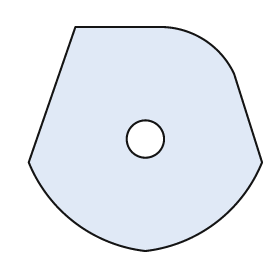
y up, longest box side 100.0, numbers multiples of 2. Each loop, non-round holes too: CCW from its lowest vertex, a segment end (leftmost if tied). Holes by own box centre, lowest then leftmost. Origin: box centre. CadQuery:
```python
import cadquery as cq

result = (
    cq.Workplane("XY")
    .moveTo(0.0, -48.0)
    .threePointArc((30.0, -36.0), (50.0, -10.0))
    .lineTo(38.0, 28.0)
    .threePointArc((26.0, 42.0), (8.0, 48.0))
    .lineTo(-30.0, 48.0)
    .lineTo(-50.0, -10.0)
    .threePointArc((-30.0, -36.0), (0.0, -48.0))
    .close()
    .moveTo(0.0, 0.0)
    .circle(8.0)
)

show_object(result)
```